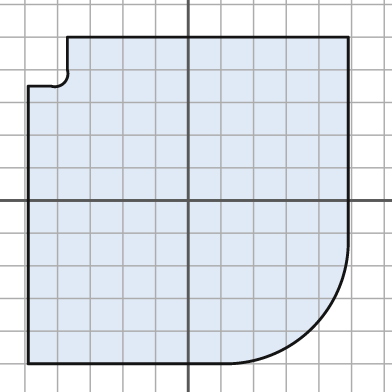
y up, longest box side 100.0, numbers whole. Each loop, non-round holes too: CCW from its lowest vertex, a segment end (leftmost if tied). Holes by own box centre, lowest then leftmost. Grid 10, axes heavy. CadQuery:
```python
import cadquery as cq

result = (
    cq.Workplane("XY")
    .moveTo(-49.0, -50.0)
    .lineTo(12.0, -50.0)
    .threePointArc((38.0, -39.0), (49.0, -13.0))
    .lineTo(49.0, 50.0)
    .lineTo(-37.0, 50.0)
    .lineTo(-37.0, 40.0)
    .threePointArc((-38.0, 36.0), (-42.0, 35.0))
    .lineTo(-49.0, 35.0)
    .close()
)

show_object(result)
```